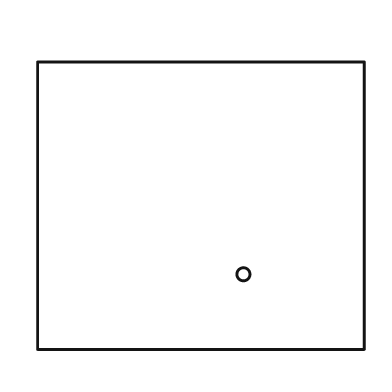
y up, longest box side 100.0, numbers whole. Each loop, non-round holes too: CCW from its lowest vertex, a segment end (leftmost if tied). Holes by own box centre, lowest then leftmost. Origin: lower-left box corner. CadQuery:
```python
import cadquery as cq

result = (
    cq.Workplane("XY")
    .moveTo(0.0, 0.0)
    .lineTo(100.0, 0.0)
    .lineTo(100.0, 88.0)
    .lineTo(0.0, 88.0)
    .close()
    .moveTo(63.0, 23.0)
    .circle(2.0)
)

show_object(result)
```